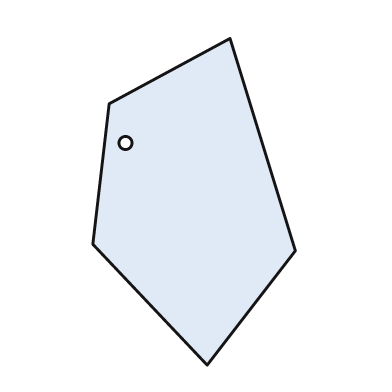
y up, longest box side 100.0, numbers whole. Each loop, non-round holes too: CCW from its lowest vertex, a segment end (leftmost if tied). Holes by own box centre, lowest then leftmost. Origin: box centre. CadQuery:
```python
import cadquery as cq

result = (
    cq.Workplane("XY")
    .moveTo(4.0, -50.0)
    .lineTo(31.0, -15.0)
    .lineTo(11.0, 50.0)
    .lineTo(-26.0, 30.0)
    .lineTo(-31.0, -13.0)
    .close()
    .moveTo(-21.0, 18.0)
    .circle(2.0)
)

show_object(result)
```